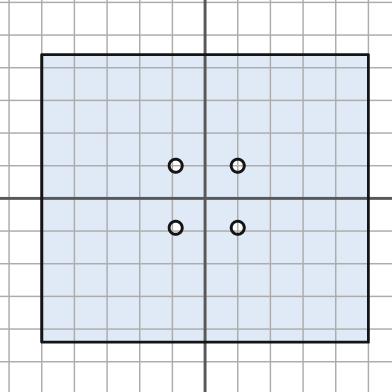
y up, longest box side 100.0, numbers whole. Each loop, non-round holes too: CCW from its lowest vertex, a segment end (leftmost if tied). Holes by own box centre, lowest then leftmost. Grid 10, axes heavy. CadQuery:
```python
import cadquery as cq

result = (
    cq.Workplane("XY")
    .moveTo(-50.0, -44.0)
    .lineTo(50.0, -44.0)
    .lineTo(50.0, 44.0)
    .lineTo(-50.0, 44.0)
    .close()
    .moveTo(-9.0, -9.0)
    .circle(2.0)
    .moveTo(10.0, -9.0)
    .circle(2.0)
    .moveTo(-9.0, 10.0)
    .circle(2.0)
    .moveTo(10.0, 10.0)
    .circle(2.0)
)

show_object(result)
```